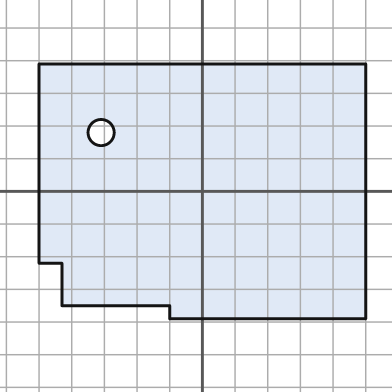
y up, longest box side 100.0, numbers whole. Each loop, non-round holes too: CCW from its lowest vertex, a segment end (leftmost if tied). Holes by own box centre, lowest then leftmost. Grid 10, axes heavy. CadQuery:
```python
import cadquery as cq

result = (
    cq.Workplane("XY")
    .moveTo(-10.0, -39.0)
    .lineTo(50.0, -39.0)
    .lineTo(50.0, 39.0)
    .lineTo(-50.0, 39.0)
    .lineTo(-50.0, -22.0)
    .lineTo(-43.0, -22.0)
    .lineTo(-43.0, -35.0)
    .lineTo(-10.0, -35.0)
    .close()
    .moveTo(-31.0, 18.0)
    .circle(4.0)
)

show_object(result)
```